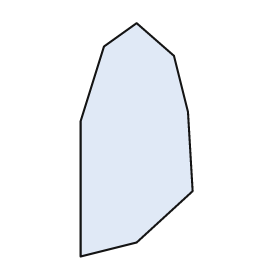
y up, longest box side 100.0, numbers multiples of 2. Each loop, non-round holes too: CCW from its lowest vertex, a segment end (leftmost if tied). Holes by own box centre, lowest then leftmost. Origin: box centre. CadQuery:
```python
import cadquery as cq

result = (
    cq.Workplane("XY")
    .moveTo(-24.0, -50.0)
    .lineTo(0.0, -44.0)
    .lineTo(24.0, -22.0)
    .lineTo(22.0, 12.0)
    .lineTo(16.0, 36.0)
    .lineTo(0.0, 50.0)
    .lineTo(-14.0, 40.0)
    .lineTo(-24.0, 8.0)
    .close()
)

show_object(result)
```